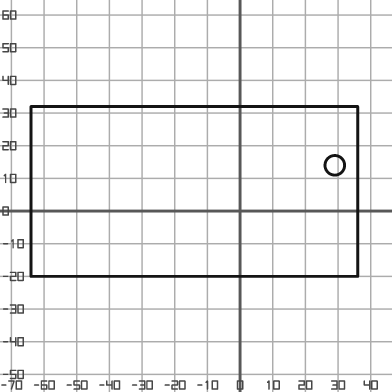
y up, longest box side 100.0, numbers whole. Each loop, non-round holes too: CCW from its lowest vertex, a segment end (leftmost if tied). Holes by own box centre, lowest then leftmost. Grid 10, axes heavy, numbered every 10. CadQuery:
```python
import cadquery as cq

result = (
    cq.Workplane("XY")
    .moveTo(-64.0, -20.0)
    .lineTo(36.0, -20.0)
    .lineTo(36.0, 32.0)
    .lineTo(-64.0, 32.0)
    .close()
    .moveTo(29.0, 14.0)
    .circle(3.0)
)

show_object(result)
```